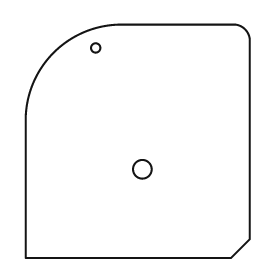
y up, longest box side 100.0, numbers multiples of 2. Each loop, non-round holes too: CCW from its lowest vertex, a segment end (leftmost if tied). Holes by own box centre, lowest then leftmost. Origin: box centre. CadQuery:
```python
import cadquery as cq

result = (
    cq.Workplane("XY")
    .moveTo(-48.0, -50.0)
    .lineTo(40.0, -50.0)
    .lineTo(48.0, -42.0)
    .lineTo(48.0, 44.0)
    .threePointArc((46.0, 48.0), (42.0, 50.0))
    .lineTo(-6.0, 50.0)
    .threePointArc((-36.0, 38.0), (-48.0, 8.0))
    .close()
    .moveTo(2.0, -12.0)
    .circle(4.0)
    .moveTo(-18.0, 40.0)
    .circle(2.0)
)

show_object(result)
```